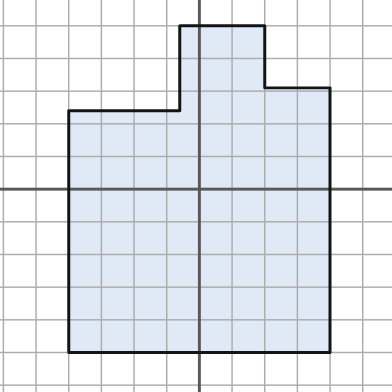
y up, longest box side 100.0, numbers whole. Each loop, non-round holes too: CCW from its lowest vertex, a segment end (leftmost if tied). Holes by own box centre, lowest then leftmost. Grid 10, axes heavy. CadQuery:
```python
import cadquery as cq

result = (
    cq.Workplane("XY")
    .moveTo(-40.0, -50.0)
    .lineTo(40.0, -50.0)
    .lineTo(40.0, 31.0)
    .lineTo(20.0, 31.0)
    .lineTo(20.0, 50.0)
    .lineTo(-6.0, 50.0)
    .lineTo(-6.0, 24.0)
    .lineTo(-40.0, 24.0)
    .close()
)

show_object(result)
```